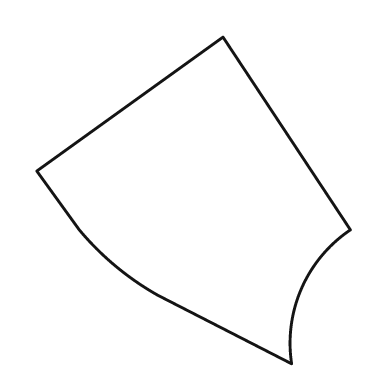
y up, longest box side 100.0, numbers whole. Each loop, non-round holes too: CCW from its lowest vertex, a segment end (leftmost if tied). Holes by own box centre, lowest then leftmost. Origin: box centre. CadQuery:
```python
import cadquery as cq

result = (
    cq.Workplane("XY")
    .moveTo(30.0, -50.0)
    .threePointArc((33.0, -27.0), (48.0, -9.0))
    .lineTo(9.0, 50.0)
    .lineTo(-48.0, 9.0)
    .lineTo(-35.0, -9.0)
    .threePointArc((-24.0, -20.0), (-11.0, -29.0))
    .close()
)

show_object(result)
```